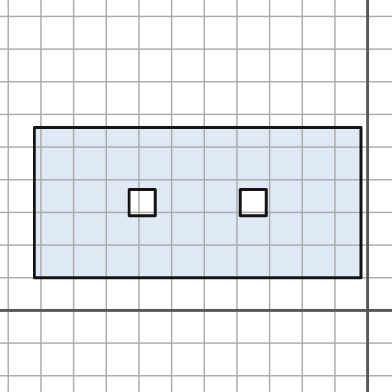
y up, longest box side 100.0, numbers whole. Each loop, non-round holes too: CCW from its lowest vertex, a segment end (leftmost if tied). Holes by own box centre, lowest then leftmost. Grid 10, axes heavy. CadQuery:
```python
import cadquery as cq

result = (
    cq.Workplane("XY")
    .moveTo(-102.0, 10.0)
    .lineTo(-2.0, 10.0)
    .lineTo(-2.0, 56.0)
    .lineTo(-102.0, 56.0)
    .close()
    .moveTo(-73.0, 29.0)
    .lineTo(-65.0, 29.0)
    .lineTo(-65.0, 37.0)
    .lineTo(-73.0, 37.0)
    .close()
    .moveTo(-39.0, 29.0)
    .lineTo(-31.0, 29.0)
    .lineTo(-31.0, 37.0)
    .lineTo(-39.0, 37.0)
    .close()
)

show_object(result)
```